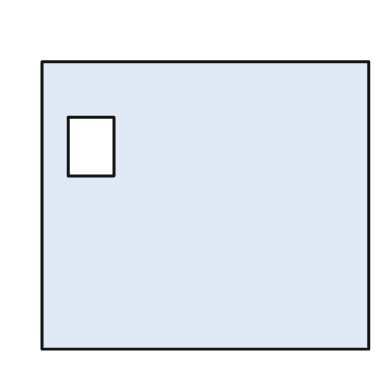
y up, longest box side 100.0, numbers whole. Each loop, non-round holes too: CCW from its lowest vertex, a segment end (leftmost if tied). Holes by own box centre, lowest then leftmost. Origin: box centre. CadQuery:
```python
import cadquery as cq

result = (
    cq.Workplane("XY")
    .moveTo(-50.0, -44.0)
    .lineTo(50.0, -44.0)
    .lineTo(50.0, 44.0)
    .lineTo(-50.0, 44.0)
    .close()
    .moveTo(-42.0, 9.0)
    .lineTo(-28.0, 9.0)
    .lineTo(-28.0, 27.0)
    .lineTo(-42.0, 27.0)
    .close()
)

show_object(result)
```